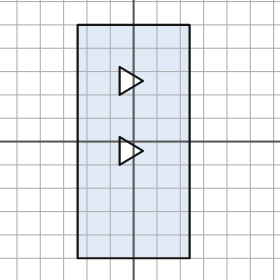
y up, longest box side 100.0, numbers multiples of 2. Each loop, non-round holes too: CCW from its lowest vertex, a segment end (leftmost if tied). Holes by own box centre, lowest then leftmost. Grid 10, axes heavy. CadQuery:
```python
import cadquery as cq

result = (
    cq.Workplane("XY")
    .moveTo(-24.0, -50.0)
    .lineTo(24.0, -50.0)
    .lineTo(24.0, 50.0)
    .lineTo(-24.0, 50.0)
    .close()
    .moveTo(-6.0, -10.0)
    .lineTo(4.0, -4.0)
    .lineTo(-6.0, 2.0)
    .close()
    .moveTo(-6.0, 20.0)
    .lineTo(4.0, 26.0)
    .lineTo(-6.0, 32.0)
    .close()
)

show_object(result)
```